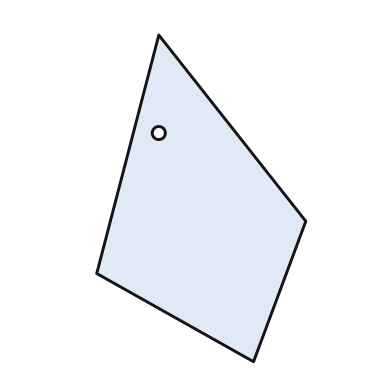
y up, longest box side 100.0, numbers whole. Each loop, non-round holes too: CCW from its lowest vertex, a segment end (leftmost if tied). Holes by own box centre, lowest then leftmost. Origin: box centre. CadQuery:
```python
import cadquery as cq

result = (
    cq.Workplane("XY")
    .moveTo(16.0, -50.0)
    .lineTo(32.0, -7.0)
    .lineTo(-13.0, 50.0)
    .lineTo(-32.0, -23.0)
    .close()
    .moveTo(-13.0, 20.0)
    .circle(2.0)
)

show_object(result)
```